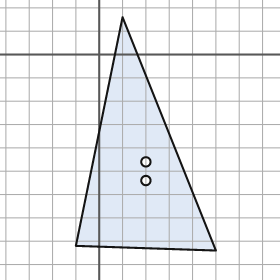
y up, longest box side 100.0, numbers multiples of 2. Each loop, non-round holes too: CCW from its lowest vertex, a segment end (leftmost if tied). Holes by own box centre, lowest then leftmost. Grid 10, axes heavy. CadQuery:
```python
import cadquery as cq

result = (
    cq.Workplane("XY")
    .moveTo(50.0, -84.0)
    .lineTo(10.0, 16.0)
    .lineTo(-10.0, -82.0)
    .close()
    .moveTo(20.0, -54.0)
    .circle(2.0)
    .moveTo(20.0, -46.0)
    .circle(2.0)
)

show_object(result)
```